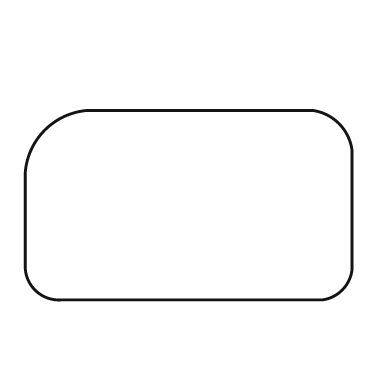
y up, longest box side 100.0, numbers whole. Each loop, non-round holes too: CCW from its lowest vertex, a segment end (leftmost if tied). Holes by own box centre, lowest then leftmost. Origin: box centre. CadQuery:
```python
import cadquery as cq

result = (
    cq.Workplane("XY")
    .moveTo(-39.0, -29.0)
    .lineTo(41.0, -29.0)
    .threePointArc((47.0, -26.0), (50.0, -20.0))
    .lineTo(50.0, 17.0)
    .threePointArc((46.0, 25.0), (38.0, 29.0))
    .lineTo(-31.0, 29.0)
    .threePointArc((-44.0, 23.0), (-50.0, 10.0))
    .lineTo(-50.0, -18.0)
    .threePointArc((-47.0, -26.0), (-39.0, -29.0))
    .close()
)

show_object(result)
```